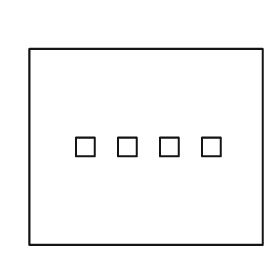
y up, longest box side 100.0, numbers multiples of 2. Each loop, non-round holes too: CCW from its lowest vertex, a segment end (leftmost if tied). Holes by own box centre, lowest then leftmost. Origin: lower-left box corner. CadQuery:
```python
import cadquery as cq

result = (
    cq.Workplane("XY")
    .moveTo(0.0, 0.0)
    .lineTo(100.0, 0.0)
    .lineTo(100.0, 84.0)
    .lineTo(0.0, 84.0)
    .close()
    .moveTo(20.0, 38.0)
    .lineTo(28.0, 38.0)
    .lineTo(28.0, 46.0)
    .lineTo(20.0, 46.0)
    .close()
    .moveTo(38.0, 38.0)
    .lineTo(46.0, 38.0)
    .lineTo(46.0, 46.0)
    .lineTo(38.0, 46.0)
    .close()
    .moveTo(56.0, 38.0)
    .lineTo(64.0, 38.0)
    .lineTo(64.0, 46.0)
    .lineTo(56.0, 46.0)
    .close()
    .moveTo(74.0, 38.0)
    .lineTo(82.0, 38.0)
    .lineTo(82.0, 46.0)
    .lineTo(74.0, 46.0)
    .close()
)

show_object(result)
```